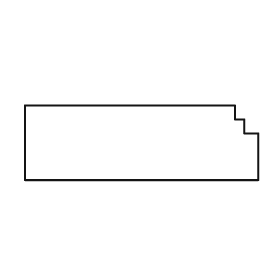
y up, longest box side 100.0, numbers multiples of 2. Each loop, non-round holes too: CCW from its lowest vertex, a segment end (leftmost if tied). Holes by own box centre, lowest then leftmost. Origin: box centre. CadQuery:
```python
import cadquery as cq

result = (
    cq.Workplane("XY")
    .moveTo(-50.0, -16.0)
    .lineTo(50.0, -16.0)
    .lineTo(50.0, 4.0)
    .lineTo(44.0, 4.0)
    .lineTo(44.0, 10.0)
    .lineTo(40.0, 10.0)
    .lineTo(40.0, 16.0)
    .lineTo(-50.0, 16.0)
    .close()
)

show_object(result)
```